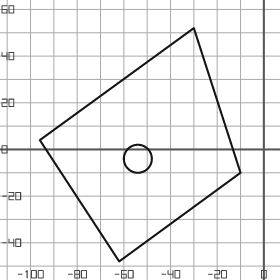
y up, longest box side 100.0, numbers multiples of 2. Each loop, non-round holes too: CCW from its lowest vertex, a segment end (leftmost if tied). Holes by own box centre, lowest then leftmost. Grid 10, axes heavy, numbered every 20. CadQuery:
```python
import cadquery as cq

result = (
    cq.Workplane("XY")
    .moveTo(-62.0, -48.0)
    .lineTo(-10.0, -10.0)
    .lineTo(-30.0, 52.0)
    .lineTo(-96.0, 4.0)
    .close()
    .moveTo(-54.0, -4.0)
    .circle(6.0)
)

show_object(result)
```